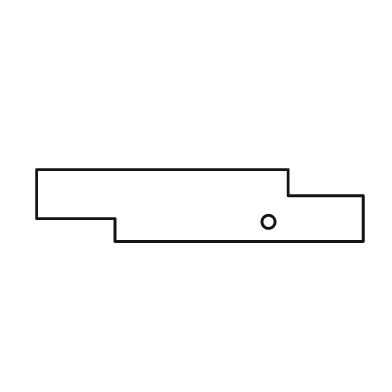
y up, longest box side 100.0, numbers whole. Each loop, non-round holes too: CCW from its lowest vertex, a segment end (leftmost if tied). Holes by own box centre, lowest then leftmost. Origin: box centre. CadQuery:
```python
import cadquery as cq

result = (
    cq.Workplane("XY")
    .moveTo(-26.0, -11.0)
    .lineTo(50.0, -11.0)
    .lineTo(50.0, 3.0)
    .lineTo(27.0, 3.0)
    .lineTo(27.0, 11.0)
    .lineTo(-50.0, 11.0)
    .lineTo(-50.0, -4.0)
    .lineTo(-26.0, -4.0)
    .close()
    .moveTo(21.0, -5.0)
    .circle(2.0)
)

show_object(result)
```